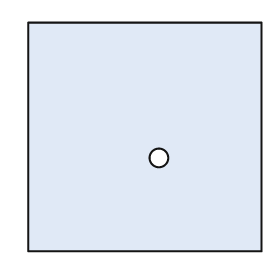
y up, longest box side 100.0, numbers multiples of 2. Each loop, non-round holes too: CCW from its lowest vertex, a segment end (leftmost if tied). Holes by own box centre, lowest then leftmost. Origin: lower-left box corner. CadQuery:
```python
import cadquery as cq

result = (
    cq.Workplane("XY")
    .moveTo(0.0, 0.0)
    .lineTo(100.0, 0.0)
    .lineTo(100.0, 98.0)
    .lineTo(0.0, 98.0)
    .close()
    .moveTo(56.0, 40.0)
    .circle(4.0)
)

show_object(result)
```